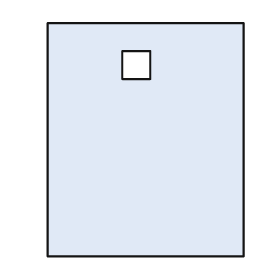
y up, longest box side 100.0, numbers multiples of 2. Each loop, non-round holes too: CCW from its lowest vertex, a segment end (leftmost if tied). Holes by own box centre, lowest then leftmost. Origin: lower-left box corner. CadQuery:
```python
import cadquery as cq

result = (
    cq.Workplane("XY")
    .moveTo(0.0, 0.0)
    .lineTo(84.0, 0.0)
    .lineTo(84.0, 100.0)
    .lineTo(0.0, 100.0)
    .close()
    .moveTo(32.0, 76.0)
    .lineTo(44.0, 76.0)
    .lineTo(44.0, 88.0)
    .lineTo(32.0, 88.0)
    .close()
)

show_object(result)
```